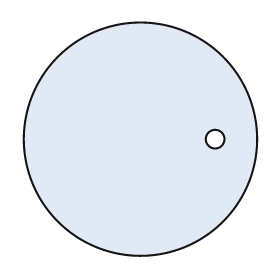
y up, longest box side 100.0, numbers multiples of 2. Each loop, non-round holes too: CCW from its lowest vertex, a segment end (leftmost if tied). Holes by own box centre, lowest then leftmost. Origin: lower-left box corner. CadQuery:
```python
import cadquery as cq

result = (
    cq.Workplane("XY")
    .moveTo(50.0, 50.0)
    .circle(50.0)
    .moveTo(82.0, 50.0)
    .circle(4.0)
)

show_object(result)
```